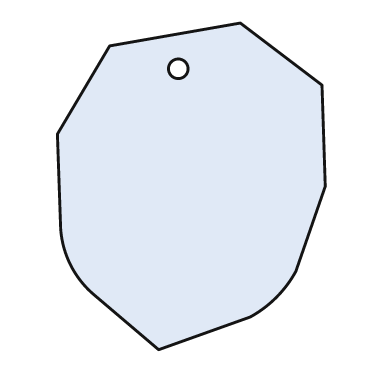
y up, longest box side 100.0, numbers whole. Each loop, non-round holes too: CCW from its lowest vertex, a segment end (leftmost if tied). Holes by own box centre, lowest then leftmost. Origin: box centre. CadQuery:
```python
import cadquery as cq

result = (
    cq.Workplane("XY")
    .moveTo(-10.0, -50.0)
    .lineTo(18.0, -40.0)
    .threePointArc((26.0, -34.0), (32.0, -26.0))
    .lineTo(41.0, 0.0)
    .lineTo(40.0, 31.0)
    .lineTo(15.0, 50.0)
    .lineTo(-25.0, 43.0)
    .lineTo(-41.0, 16.0)
    .lineTo(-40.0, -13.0)
    .threePointArc((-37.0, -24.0), (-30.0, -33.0))
    .close()
    .moveTo(-4.0, 36.0)
    .circle(3.0)
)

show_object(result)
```